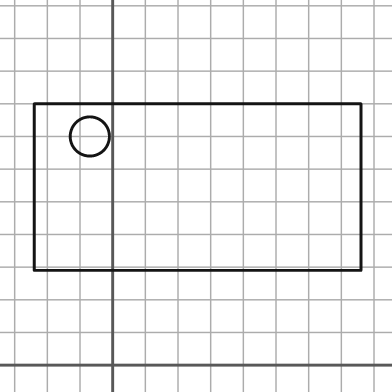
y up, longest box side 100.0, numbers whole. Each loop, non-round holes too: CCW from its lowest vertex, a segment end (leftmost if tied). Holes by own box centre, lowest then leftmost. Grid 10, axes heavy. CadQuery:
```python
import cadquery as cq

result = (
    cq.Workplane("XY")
    .moveTo(-24.0, 29.0)
    .lineTo(76.0, 29.0)
    .lineTo(76.0, 80.0)
    .lineTo(-24.0, 80.0)
    .close()
    .moveTo(-7.0, 70.0)
    .circle(6.0)
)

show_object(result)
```